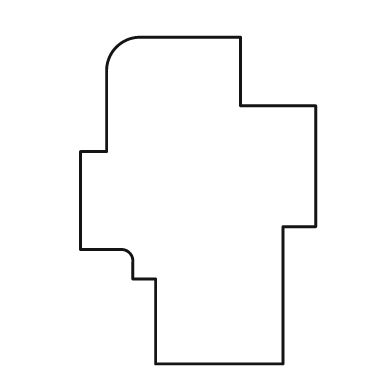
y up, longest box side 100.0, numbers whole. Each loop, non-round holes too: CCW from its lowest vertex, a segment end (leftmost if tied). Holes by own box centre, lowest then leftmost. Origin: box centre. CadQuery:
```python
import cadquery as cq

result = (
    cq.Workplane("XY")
    .moveTo(-13.0, -50.0)
    .lineTo(26.0, -50.0)
    .lineTo(26.0, -8.0)
    .lineTo(36.0, -8.0)
    .lineTo(36.0, 29.0)
    .lineTo(13.0, 29.0)
    .lineTo(13.0, 50.0)
    .lineTo(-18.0, 50.0)
    .threePointArc((-25.0, 47.0), (-28.0, 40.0))
    .lineTo(-28.0, 15.0)
    .lineTo(-36.0, 15.0)
    .lineTo(-36.0, -15.0)
    .lineTo(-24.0, -15.0)
    .threePointArc((-21.0, -16.0), (-20.0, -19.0))
    .lineTo(-20.0, -24.0)
    .lineTo(-13.0, -24.0)
    .close()
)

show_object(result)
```